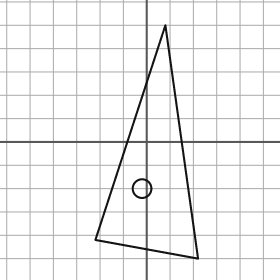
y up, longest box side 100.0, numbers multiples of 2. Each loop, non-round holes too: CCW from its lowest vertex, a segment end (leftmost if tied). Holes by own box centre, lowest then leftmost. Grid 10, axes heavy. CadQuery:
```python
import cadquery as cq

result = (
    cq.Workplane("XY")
    .moveTo(22.0, -50.0)
    .lineTo(8.0, 50.0)
    .lineTo(-22.0, -42.0)
    .close()
    .moveTo(-2.0, -20.0)
    .circle(4.0)
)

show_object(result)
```